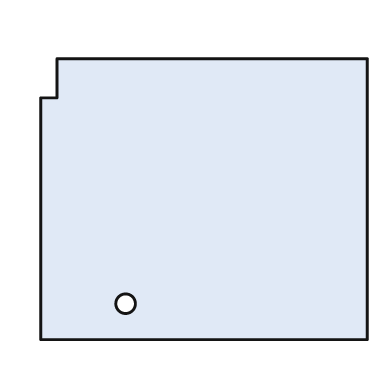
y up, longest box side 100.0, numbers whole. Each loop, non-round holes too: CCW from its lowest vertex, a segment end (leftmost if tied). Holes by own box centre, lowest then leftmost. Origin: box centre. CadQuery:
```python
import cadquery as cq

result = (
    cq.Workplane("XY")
    .moveTo(-50.0, -43.0)
    .lineTo(50.0, -43.0)
    .lineTo(50.0, 43.0)
    .lineTo(-45.0, 43.0)
    .lineTo(-45.0, 31.0)
    .lineTo(-50.0, 31.0)
    .close()
    .moveTo(-24.0, -32.0)
    .circle(3.0)
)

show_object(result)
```